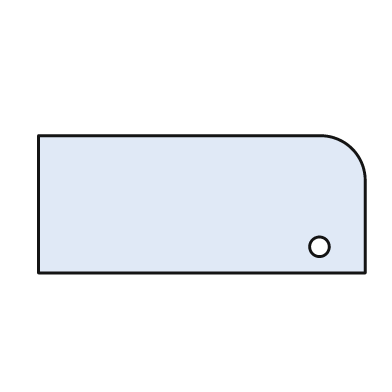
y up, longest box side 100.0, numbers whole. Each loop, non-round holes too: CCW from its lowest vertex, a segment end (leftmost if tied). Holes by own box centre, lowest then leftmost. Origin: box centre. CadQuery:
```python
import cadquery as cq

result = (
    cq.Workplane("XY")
    .moveTo(-50.0, -21.0)
    .lineTo(50.0, -21.0)
    .lineTo(50.0, 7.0)
    .threePointArc((46.0, 17.0), (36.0, 21.0))
    .lineTo(-50.0, 21.0)
    .close()
    .moveTo(36.0, -13.0)
    .circle(3.0)
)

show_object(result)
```